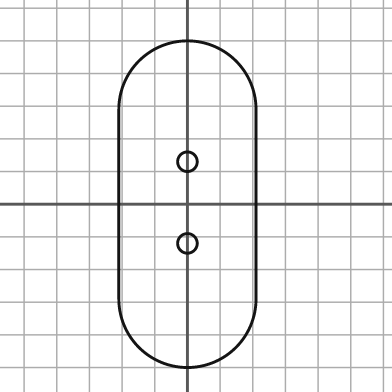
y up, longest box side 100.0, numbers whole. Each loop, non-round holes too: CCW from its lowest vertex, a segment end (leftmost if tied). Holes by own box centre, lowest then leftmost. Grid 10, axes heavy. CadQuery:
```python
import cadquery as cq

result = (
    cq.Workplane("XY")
    .moveTo(-21.0, -29.0)
    .threePointArc((0.0, -50.0), (21.0, -29.0))
    .lineTo(21.0, 29.0)
    .threePointArc((0.0, 50.0), (-21.0, 29.0))
    .close()
    .moveTo(0.0, -12.0)
    .circle(3.0)
    .moveTo(0.0, 13.0)
    .circle(3.0)
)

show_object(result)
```